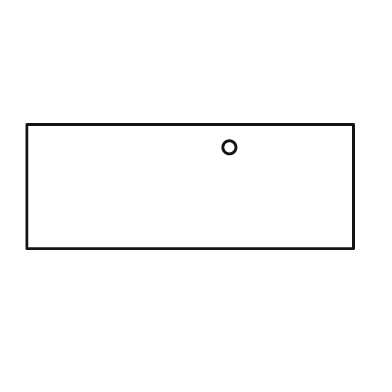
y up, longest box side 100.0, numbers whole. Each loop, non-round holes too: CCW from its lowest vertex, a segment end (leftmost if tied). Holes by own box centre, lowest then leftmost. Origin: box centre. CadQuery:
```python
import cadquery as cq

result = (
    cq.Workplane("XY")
    .moveTo(-50.0, -19.0)
    .lineTo(50.0, -19.0)
    .lineTo(50.0, 19.0)
    .lineTo(-50.0, 19.0)
    .close()
    .moveTo(12.0, 12.0)
    .circle(2.0)
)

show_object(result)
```